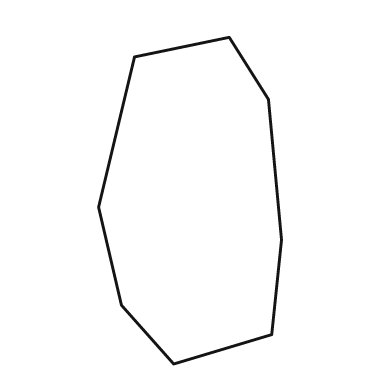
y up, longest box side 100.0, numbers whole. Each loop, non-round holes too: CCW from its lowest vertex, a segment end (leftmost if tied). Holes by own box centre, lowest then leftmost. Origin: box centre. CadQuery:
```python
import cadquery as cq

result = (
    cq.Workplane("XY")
    .moveTo(-5.0, -50.0)
    .lineTo(25.0, -41.0)
    .lineTo(28.0, -12.0)
    .lineTo(24.0, 31.0)
    .lineTo(12.0, 50.0)
    .lineTo(-17.0, 44.0)
    .lineTo(-28.0, -2.0)
    .lineTo(-21.0, -32.0)
    .close()
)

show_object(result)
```